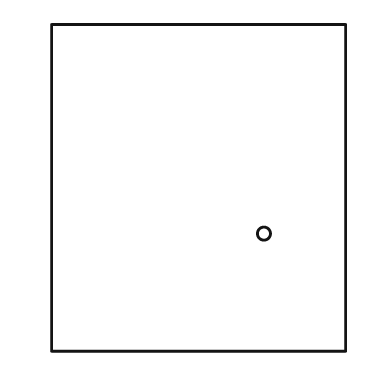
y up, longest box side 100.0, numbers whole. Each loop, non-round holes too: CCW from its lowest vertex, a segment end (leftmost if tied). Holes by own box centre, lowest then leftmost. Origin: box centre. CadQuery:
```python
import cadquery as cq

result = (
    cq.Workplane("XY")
    .moveTo(-45.0, -50.0)
    .lineTo(45.0, -50.0)
    .lineTo(45.0, 50.0)
    .lineTo(-45.0, 50.0)
    .close()
    .moveTo(20.0, -14.0)
    .circle(2.0)
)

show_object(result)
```